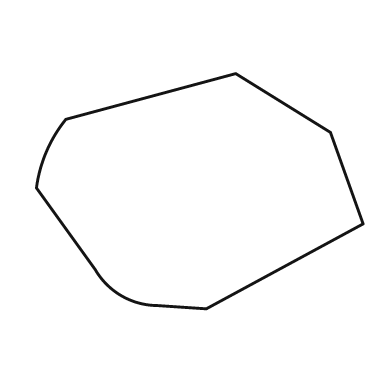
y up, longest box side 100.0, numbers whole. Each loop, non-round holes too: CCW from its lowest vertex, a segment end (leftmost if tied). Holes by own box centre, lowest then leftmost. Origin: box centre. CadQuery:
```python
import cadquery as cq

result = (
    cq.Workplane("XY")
    .moveTo(2.0, -36.0)
    .lineTo(50.0, -10.0)
    .lineTo(40.0, 18.0)
    .lineTo(11.0, 36.0)
    .lineTo(-41.0, 22.0)
    .threePointArc((-47.0, 12.0), (-50.0, 1.0))
    .lineTo(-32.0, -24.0)
    .threePointArc((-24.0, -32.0), (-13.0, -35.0))
    .close()
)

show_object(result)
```